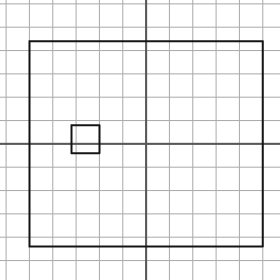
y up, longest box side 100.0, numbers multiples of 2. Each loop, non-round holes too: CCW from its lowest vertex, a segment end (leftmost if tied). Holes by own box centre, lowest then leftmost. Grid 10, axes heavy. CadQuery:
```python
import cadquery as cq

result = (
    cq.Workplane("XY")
    .moveTo(-50.0, -44.0)
    .lineTo(50.0, -44.0)
    .lineTo(50.0, 44.0)
    .lineTo(-50.0, 44.0)
    .close()
    .moveTo(-32.0, -4.0)
    .lineTo(-20.0, -4.0)
    .lineTo(-20.0, 8.0)
    .lineTo(-32.0, 8.0)
    .close()
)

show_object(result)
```